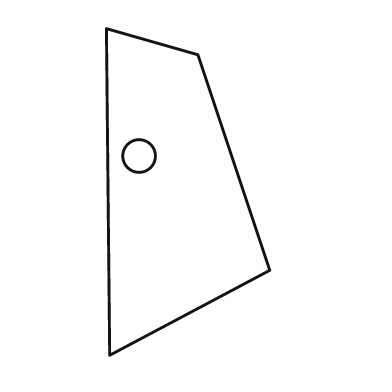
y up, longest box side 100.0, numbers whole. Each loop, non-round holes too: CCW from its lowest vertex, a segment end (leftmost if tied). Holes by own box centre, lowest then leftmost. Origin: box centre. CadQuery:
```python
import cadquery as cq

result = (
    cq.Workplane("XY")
    .moveTo(-24.0, -50.0)
    .lineTo(25.0, -24.0)
    .lineTo(3.0, 42.0)
    .lineTo(-25.0, 50.0)
    .close()
    .moveTo(-15.0, 11.0)
    .circle(5.0)
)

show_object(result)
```